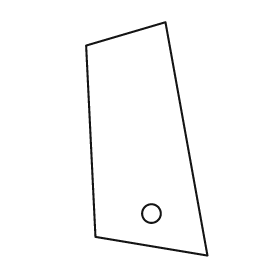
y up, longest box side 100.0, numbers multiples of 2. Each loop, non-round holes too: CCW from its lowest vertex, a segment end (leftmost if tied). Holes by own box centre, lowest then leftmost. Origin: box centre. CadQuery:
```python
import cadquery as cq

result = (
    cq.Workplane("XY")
    .moveTo(26.0, -50.0)
    .lineTo(8.0, 50.0)
    .lineTo(-26.0, 40.0)
    .lineTo(-22.0, -42.0)
    .close()
    .moveTo(2.0, -32.0)
    .circle(4.0)
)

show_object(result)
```